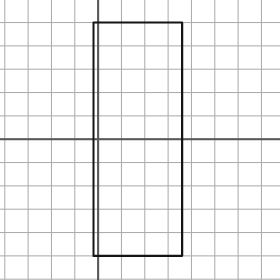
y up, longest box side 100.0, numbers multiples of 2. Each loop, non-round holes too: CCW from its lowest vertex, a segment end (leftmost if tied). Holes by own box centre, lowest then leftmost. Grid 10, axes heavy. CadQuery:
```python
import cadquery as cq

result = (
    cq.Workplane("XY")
    .moveTo(-2.0, -50.0)
    .lineTo(36.0, -50.0)
    .lineTo(36.0, 50.0)
    .lineTo(-2.0, 50.0)
    .close()
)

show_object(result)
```